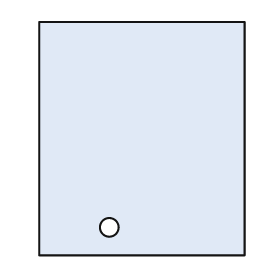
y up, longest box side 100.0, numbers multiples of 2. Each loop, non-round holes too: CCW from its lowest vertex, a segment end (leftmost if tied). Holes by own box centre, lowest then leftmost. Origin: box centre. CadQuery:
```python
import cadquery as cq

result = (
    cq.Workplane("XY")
    .moveTo(-44.0, -50.0)
    .lineTo(44.0, -50.0)
    .lineTo(44.0, 50.0)
    .lineTo(-44.0, 50.0)
    .close()
    .moveTo(-14.0, -38.0)
    .circle(4.0)
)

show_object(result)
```